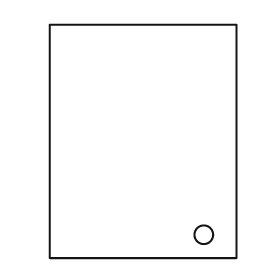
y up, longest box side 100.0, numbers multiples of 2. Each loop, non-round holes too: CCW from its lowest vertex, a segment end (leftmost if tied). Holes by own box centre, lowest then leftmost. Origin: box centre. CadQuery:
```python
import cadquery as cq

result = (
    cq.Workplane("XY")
    .moveTo(-40.0, -50.0)
    .lineTo(40.0, -50.0)
    .lineTo(40.0, 50.0)
    .lineTo(-40.0, 50.0)
    .close()
    .moveTo(26.0, -40.0)
    .circle(4.0)
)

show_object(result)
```